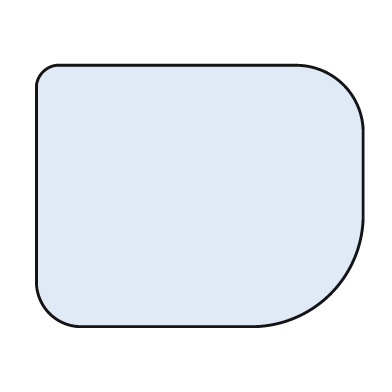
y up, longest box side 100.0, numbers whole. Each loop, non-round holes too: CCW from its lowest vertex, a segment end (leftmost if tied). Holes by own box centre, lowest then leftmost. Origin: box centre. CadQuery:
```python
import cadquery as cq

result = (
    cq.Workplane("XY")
    .moveTo(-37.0, -40.0)
    .lineTo(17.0, -40.0)
    .threePointArc((40.0, -30.0), (50.0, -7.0))
    .lineTo(50.0, 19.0)
    .threePointArc((44.0, 34.0), (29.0, 40.0))
    .lineTo(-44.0, 40.0)
    .threePointArc((-48.0, 38.0), (-50.0, 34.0))
    .lineTo(-50.0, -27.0)
    .threePointArc((-46.0, -36.0), (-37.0, -40.0))
    .close()
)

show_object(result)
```